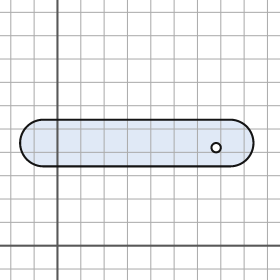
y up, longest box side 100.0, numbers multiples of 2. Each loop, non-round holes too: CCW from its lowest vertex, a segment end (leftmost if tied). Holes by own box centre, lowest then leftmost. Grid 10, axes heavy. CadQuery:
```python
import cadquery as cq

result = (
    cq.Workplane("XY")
    .moveTo(-6.0, 34.0)
    .lineTo(74.0, 34.0)
    .threePointArc((84.0, 44.0), (74.0, 54.0))
    .lineTo(-6.0, 54.0)
    .threePointArc((-16.0, 44.0), (-6.0, 34.0))
    .close()
    .moveTo(68.0, 42.0)
    .circle(2.0)
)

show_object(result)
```